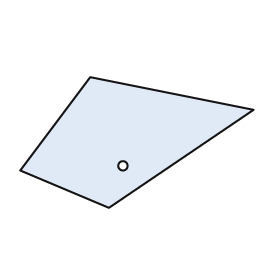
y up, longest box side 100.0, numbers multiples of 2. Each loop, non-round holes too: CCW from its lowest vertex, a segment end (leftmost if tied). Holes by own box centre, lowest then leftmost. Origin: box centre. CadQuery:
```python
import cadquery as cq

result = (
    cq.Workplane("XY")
    .moveTo(-12.0, -28.0)
    .lineTo(50.0, 14.0)
    .lineTo(-20.0, 28.0)
    .lineTo(-50.0, -12.0)
    .close()
    .moveTo(-6.0, -10.0)
    .circle(2.0)
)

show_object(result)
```